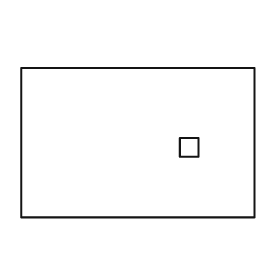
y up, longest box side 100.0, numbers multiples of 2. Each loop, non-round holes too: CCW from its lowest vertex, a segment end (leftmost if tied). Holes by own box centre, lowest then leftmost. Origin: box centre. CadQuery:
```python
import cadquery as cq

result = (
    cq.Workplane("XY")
    .moveTo(-50.0, -32.0)
    .lineTo(50.0, -32.0)
    .lineTo(50.0, 32.0)
    .lineTo(-50.0, 32.0)
    .close()
    .moveTo(18.0, -6.0)
    .lineTo(26.0, -6.0)
    .lineTo(26.0, 2.0)
    .lineTo(18.0, 2.0)
    .close()
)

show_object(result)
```